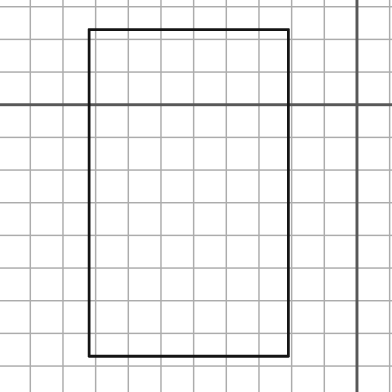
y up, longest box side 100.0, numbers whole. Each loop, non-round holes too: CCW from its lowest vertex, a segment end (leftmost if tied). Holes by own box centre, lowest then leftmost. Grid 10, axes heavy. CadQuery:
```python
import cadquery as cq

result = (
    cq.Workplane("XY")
    .moveTo(-82.0, -77.0)
    .lineTo(-21.0, -77.0)
    .lineTo(-21.0, 23.0)
    .lineTo(-82.0, 23.0)
    .close()
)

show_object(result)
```